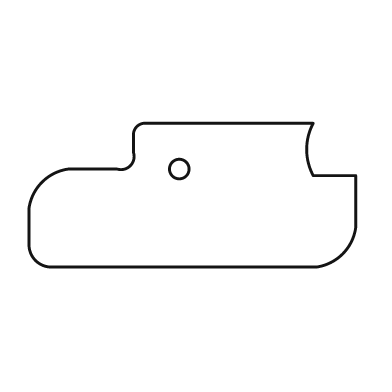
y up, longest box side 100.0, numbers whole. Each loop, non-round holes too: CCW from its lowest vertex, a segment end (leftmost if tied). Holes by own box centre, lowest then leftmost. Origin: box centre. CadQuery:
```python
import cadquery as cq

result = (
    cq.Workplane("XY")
    .moveTo(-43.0, -22.0)
    .lineTo(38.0, -22.0)
    .threePointArc((46.0, -18.0), (50.0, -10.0))
    .lineTo(50.0, 6.0)
    .lineTo(37.0, 6.0)
    .threePointArc((35.0, 14.0), (37.0, 22.0))
    .lineTo(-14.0, 22.0)
    .threePointArc((-17.0, 21.0), (-18.0, 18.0))
    .lineTo(-18.0, 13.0)
    .threePointArc((-19.0, 9.0), (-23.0, 8.0))
    .lineTo(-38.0, 8.0)
    .threePointArc((-46.0, 4.0), (-50.0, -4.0))
    .lineTo(-50.0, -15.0)
    .threePointArc((-48.0, -20.0), (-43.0, -22.0))
    .close()
    .moveTo(-4.0, 8.0)
    .circle(3.0)
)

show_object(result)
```